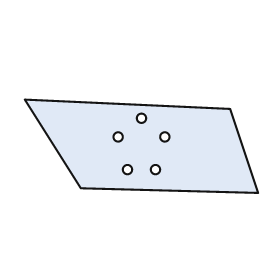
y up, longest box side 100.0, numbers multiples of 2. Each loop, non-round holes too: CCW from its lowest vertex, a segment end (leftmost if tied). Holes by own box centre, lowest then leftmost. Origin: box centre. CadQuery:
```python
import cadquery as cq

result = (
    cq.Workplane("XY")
    .moveTo(50.0, -20.0)
    .lineTo(38.0, 16.0)
    .lineTo(-50.0, 20.0)
    .lineTo(-26.0, -18.0)
    .close()
    .moveTo(-6.0, -10.0)
    .circle(2.0)
    .moveTo(6.0, -10.0)
    .circle(2.0)
    .moveTo(-10.0, 4.0)
    .circle(2.0)
    .moveTo(10.0, 4.0)
    .circle(2.0)
    .moveTo(0.0, 12.0)
    .circle(2.0)
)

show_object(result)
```